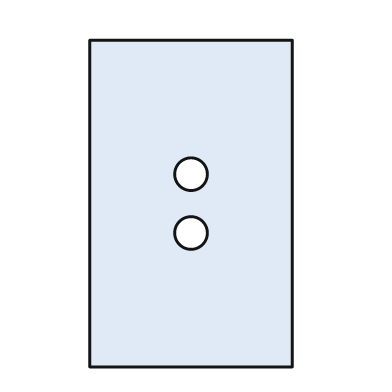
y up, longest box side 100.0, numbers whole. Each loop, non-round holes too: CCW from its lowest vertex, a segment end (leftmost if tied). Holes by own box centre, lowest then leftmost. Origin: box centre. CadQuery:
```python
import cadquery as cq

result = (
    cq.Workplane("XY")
    .moveTo(-31.0, -50.0)
    .lineTo(31.0, -50.0)
    .lineTo(31.0, 50.0)
    .lineTo(-31.0, 50.0)
    .close()
    .moveTo(0.0, -9.0)
    .circle(5.0)
    .moveTo(0.0, 9.0)
    .circle(5.0)
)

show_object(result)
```